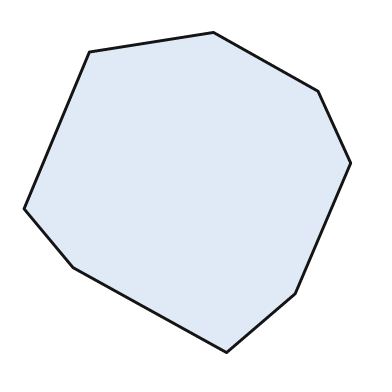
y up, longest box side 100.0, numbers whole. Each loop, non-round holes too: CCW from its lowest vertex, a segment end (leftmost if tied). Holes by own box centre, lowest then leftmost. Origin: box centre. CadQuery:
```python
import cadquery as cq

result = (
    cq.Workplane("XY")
    .moveTo(12.0, -49.0)
    .lineTo(33.0, -31.0)
    .lineTo(50.0, 9.0)
    .lineTo(40.0, 31.0)
    .lineTo(8.0, 49.0)
    .lineTo(-30.0, 43.0)
    .lineTo(-50.0, -5.0)
    .lineTo(-35.0, -23.0)
    .close()
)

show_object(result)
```